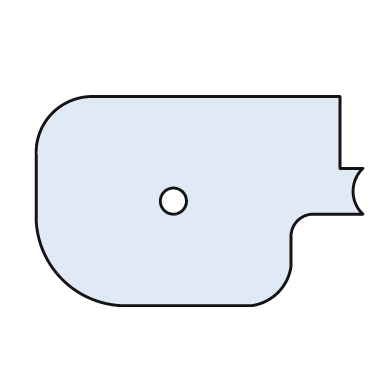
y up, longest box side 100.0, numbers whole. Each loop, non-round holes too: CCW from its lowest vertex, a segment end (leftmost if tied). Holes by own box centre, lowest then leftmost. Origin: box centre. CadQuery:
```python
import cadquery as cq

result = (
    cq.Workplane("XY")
    .moveTo(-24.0, -32.0)
    .lineTo(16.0, -32.0)
    .threePointArc((24.0, -28.0), (28.0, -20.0))
    .lineTo(28.0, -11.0)
    .threePointArc((30.0, -6.0), (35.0, -4.0))
    .lineTo(50.0, -4.0)
    .threePointArc((47.0, 3.0), (50.0, 10.0))
    .lineTo(43.0, 10.0)
    .lineTo(43.0, 32.0)
    .lineTo(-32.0, 32.0)
    .threePointArc((-45.0, 27.0), (-50.0, 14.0))
    .lineTo(-50.0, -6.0)
    .threePointArc((-42.0, -24.0), (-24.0, -32.0))
    .close()
    .moveTo(-8.0, 0.0)
    .circle(4.0)
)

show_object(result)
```